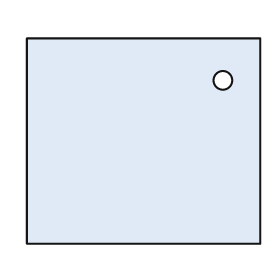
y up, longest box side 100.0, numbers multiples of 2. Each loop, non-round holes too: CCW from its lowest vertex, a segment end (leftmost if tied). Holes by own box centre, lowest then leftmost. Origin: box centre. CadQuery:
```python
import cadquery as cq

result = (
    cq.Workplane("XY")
    .moveTo(-50.0, -44.0)
    .lineTo(50.0, -44.0)
    .lineTo(50.0, 44.0)
    .lineTo(-50.0, 44.0)
    .close()
    .moveTo(34.0, 26.0)
    .circle(4.0)
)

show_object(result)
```